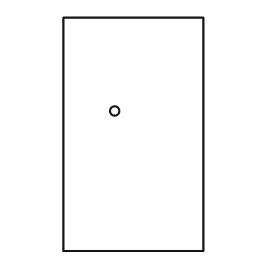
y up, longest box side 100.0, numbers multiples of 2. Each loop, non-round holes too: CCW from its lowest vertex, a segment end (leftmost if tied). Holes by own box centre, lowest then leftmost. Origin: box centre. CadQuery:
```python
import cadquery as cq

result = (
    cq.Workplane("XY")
    .moveTo(-30.0, -50.0)
    .lineTo(30.0, -50.0)
    .lineTo(30.0, 50.0)
    .lineTo(-30.0, 50.0)
    .close()
    .moveTo(-8.0, 10.0)
    .circle(2.0)
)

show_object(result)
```